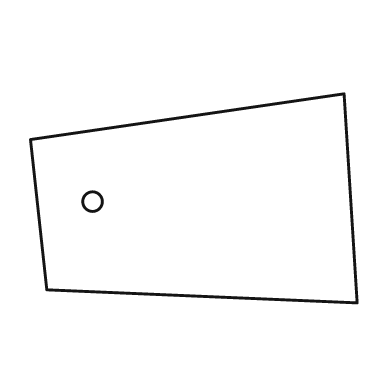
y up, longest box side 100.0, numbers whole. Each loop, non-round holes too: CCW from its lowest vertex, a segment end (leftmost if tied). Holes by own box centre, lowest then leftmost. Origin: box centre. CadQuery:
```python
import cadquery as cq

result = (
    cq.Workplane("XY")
    .moveTo(50.0, -32.0)
    .lineTo(46.0, 32.0)
    .lineTo(-50.0, 18.0)
    .lineTo(-45.0, -28.0)
    .close()
    .moveTo(-31.0, -1.0)
    .circle(3.0)
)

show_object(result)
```